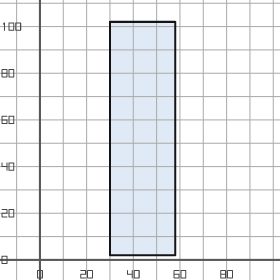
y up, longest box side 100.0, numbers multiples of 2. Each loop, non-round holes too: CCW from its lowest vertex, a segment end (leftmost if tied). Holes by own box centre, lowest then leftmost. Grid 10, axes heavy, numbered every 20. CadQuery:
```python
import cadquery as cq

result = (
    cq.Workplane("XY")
    .moveTo(30.0, 2.0)
    .lineTo(58.0, 2.0)
    .lineTo(58.0, 102.0)
    .lineTo(30.0, 102.0)
    .close()
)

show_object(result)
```